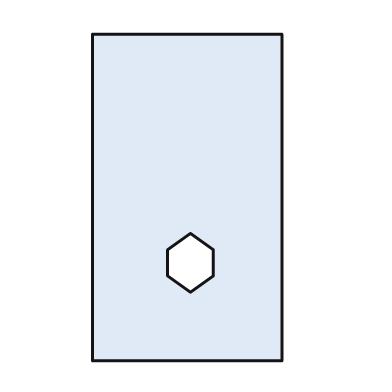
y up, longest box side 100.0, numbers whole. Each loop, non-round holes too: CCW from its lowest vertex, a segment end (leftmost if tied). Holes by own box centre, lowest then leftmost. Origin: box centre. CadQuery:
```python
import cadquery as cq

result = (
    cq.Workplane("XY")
    .moveTo(-29.0, -50.0)
    .lineTo(29.0, -50.0)
    .lineTo(29.0, 50.0)
    .lineTo(-29.0, 50.0)
    .close()
    .moveTo(1.0, -29.0)
    .lineTo(8.0, -24.0)
    .lineTo(8.0, -16.0)
    .lineTo(1.0, -11.0)
    .lineTo(-6.0, -16.0)
    .lineTo(-6.0, -24.0)
    .close()
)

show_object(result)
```